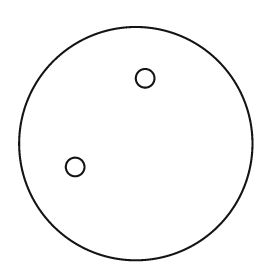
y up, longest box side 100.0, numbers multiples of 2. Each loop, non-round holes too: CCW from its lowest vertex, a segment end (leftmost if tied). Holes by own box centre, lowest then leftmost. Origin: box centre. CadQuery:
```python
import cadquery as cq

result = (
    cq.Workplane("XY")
    .moveTo(0.0, 0.0)
    .circle(50.0)
    .moveTo(-26.0, -10.0)
    .circle(4.0)
    .moveTo(4.0, 28.0)
    .circle(4.0)
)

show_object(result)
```